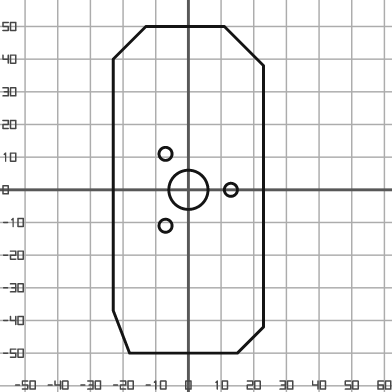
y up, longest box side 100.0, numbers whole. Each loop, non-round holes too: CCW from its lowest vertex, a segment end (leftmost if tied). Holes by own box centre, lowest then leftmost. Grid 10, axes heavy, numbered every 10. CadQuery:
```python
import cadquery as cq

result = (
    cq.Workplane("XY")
    .moveTo(-18.0, -50.0)
    .lineTo(15.0, -50.0)
    .lineTo(23.0, -42.0)
    .lineTo(23.0, 38.0)
    .lineTo(11.0, 50.0)
    .lineTo(-13.0, 50.0)
    .lineTo(-23.0, 40.0)
    .lineTo(-23.0, -37.0)
    .close()
    .moveTo(-7.0, -11.0)
    .circle(2.0)
    .moveTo(0.0, 0.0)
    .circle(6.0)
    .moveTo(13.0, 0.0)
    .circle(2.0)
    .moveTo(-7.0, 11.0)
    .circle(2.0)
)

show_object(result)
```